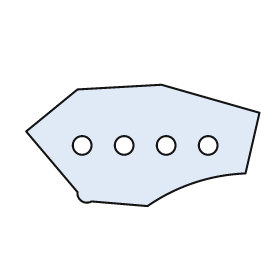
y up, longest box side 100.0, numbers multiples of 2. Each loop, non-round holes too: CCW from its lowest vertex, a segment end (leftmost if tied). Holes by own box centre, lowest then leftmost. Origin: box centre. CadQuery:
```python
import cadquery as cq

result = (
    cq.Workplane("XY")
    .moveTo(2.0, -26.0)
    .threePointArc((22.0, -16.0), (44.0, -12.0))
    .lineTo(50.0, 14.0)
    .lineTo(8.0, 26.0)
    .lineTo(-28.0, 24.0)
    .lineTo(-50.0, 6.0)
    .lineTo(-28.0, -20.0)
    .threePointArc((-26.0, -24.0), (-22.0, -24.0))
    .close()
    .moveTo(-26.0, 0.0)
    .circle(4.0)
    .moveTo(-8.0, 0.0)
    .circle(4.0)
    .moveTo(10.0, 0.0)
    .circle(4.0)
    .moveTo(28.0, 0.0)
    .circle(4.0)
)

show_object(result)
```